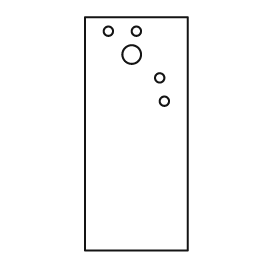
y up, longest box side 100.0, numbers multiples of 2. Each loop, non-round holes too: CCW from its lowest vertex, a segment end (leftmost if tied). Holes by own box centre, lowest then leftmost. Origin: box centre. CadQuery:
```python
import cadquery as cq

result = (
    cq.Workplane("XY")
    .moveTo(-22.0, -50.0)
    .lineTo(22.0, -50.0)
    .lineTo(22.0, 50.0)
    .lineTo(-22.0, 50.0)
    .close()
    .moveTo(12.0, 14.0)
    .circle(2.0)
    .moveTo(10.0, 24.0)
    .circle(2.0)
    .moveTo(-2.0, 34.0)
    .circle(4.0)
    .moveTo(-12.0, 44.0)
    .circle(2.0)
    .moveTo(0.0, 44.0)
    .circle(2.0)
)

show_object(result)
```